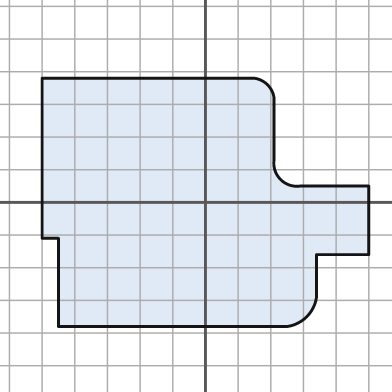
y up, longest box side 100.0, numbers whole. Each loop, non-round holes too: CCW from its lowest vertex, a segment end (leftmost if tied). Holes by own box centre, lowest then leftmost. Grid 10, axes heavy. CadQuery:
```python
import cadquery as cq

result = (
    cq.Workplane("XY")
    .moveTo(-45.0, -38.0)
    .lineTo(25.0, -38.0)
    .threePointArc((31.0, -35.0), (34.0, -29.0))
    .lineTo(34.0, -16.0)
    .lineTo(50.0, -16.0)
    .lineTo(50.0, 5.0)
    .lineTo(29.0, 5.0)
    .threePointArc((23.0, 7.0), (21.0, 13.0))
    .lineTo(21.0, 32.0)
    .threePointArc((19.0, 36.0), (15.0, 38.0))
    .lineTo(-50.0, 38.0)
    .lineTo(-50.0, -11.0)
    .lineTo(-45.0, -11.0)
    .close()
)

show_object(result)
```